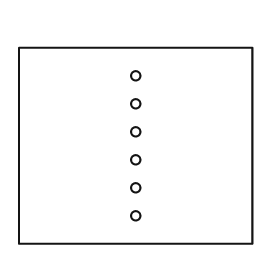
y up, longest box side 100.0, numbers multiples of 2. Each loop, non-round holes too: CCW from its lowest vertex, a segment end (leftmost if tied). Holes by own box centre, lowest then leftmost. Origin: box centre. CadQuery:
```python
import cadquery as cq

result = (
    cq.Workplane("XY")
    .moveTo(-50.0, -42.0)
    .lineTo(50.0, -42.0)
    .lineTo(50.0, 42.0)
    .lineTo(-50.0, 42.0)
    .close()
    .moveTo(0.0, -30.0)
    .circle(2.0)
    .moveTo(0.0, -18.0)
    .circle(2.0)
    .moveTo(0.0, -6.0)
    .circle(2.0)
    .moveTo(0.0, 6.0)
    .circle(2.0)
    .moveTo(0.0, 18.0)
    .circle(2.0)
    .moveTo(0.0, 30.0)
    .circle(2.0)
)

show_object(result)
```